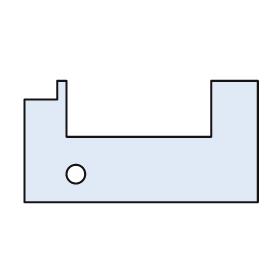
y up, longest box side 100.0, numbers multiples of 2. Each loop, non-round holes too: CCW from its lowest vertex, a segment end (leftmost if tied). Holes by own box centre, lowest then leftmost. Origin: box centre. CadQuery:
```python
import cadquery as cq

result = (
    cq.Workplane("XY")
    .moveTo(-50.0, -26.0)
    .lineTo(50.0, -26.0)
    .lineTo(50.0, 26.0)
    .lineTo(30.0, 26.0)
    .lineTo(30.0, 2.0)
    .lineTo(-32.0, 2.0)
    .lineTo(-32.0, 26.0)
    .lineTo(-36.0, 26.0)
    .lineTo(-36.0, 18.0)
    .lineTo(-50.0, 18.0)
    .close()
    .moveTo(-28.0, -14.0)
    .circle(4.0)
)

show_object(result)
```